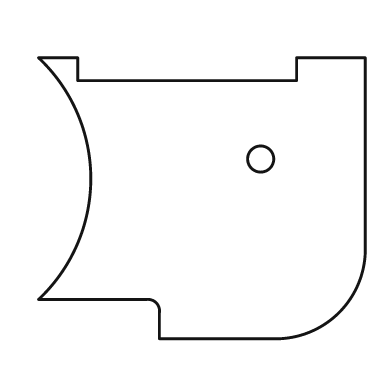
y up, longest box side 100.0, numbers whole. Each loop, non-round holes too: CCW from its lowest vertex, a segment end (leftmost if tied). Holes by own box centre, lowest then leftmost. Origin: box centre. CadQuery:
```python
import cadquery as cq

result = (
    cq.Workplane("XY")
    .moveTo(-13.0, -43.0)
    .lineTo(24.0, -43.0)
    .threePointArc((42.0, -35.0), (50.0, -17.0))
    .lineTo(50.0, 43.0)
    .lineTo(29.0, 43.0)
    .lineTo(29.0, 36.0)
    .lineTo(-38.0, 36.0)
    .lineTo(-38.0, 43.0)
    .lineTo(-50.0, 43.0)
    .threePointArc((-34.0, 6.0), (-50.0, -31.0))
    .lineTo(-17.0, -31.0)
    .threePointArc((-14.0, -32.0), (-13.0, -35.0))
    .close()
    .moveTo(18.0, 12.0)
    .circle(4.0)
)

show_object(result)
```